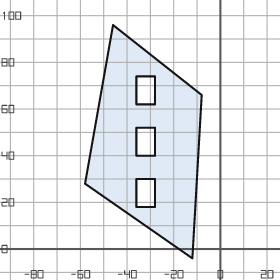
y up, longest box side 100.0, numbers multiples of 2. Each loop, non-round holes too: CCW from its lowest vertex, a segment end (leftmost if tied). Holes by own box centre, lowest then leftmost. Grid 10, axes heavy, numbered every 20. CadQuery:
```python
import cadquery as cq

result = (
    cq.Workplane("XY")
    .moveTo(-12.0, -4.0)
    .lineTo(-8.0, 66.0)
    .lineTo(-46.0, 96.0)
    .lineTo(-58.0, 28.0)
    .close()
    .moveTo(-36.0, 18.0)
    .lineTo(-28.0, 18.0)
    .lineTo(-28.0, 30.0)
    .lineTo(-36.0, 30.0)
    .close()
    .moveTo(-36.0, 40.0)
    .lineTo(-28.0, 40.0)
    .lineTo(-28.0, 52.0)
    .lineTo(-36.0, 52.0)
    .close()
    .moveTo(-36.0, 62.0)
    .lineTo(-28.0, 62.0)
    .lineTo(-28.0, 74.0)
    .lineTo(-36.0, 74.0)
    .close()
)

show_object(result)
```